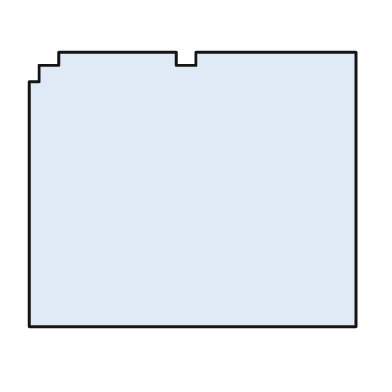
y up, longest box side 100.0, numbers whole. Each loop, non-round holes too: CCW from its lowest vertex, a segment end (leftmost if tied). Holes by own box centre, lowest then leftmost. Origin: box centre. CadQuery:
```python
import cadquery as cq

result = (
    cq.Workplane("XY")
    .moveTo(-50.0, -42.0)
    .lineTo(50.0, -42.0)
    .lineTo(50.0, 42.0)
    .lineTo(1.0, 42.0)
    .lineTo(1.0, 38.0)
    .lineTo(-5.0, 38.0)
    .lineTo(-5.0, 42.0)
    .lineTo(-41.0, 42.0)
    .lineTo(-41.0, 38.0)
    .lineTo(-47.0, 38.0)
    .lineTo(-47.0, 33.0)
    .lineTo(-50.0, 33.0)
    .close()
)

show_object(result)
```